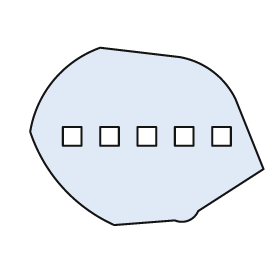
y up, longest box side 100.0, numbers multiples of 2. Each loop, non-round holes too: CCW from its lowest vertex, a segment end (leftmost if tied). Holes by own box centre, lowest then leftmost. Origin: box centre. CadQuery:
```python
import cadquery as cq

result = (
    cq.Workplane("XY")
    .moveTo(-14.0, -38.0)
    .lineTo(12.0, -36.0)
    .threePointArc((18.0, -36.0), (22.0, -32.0))
    .lineTo(50.0, -14.0)
    .lineTo(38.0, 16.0)
    .threePointArc((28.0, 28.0), (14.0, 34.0))
    .lineTo(-20.0, 38.0)
    .threePointArc((-40.0, 24.0), (-50.0, 2.0))
    .threePointArc((-36.0, -22.0), (-14.0, -38.0))
    .close()
    .moveTo(-36.0, -4.0)
    .lineTo(-28.0, -4.0)
    .lineTo(-28.0, 4.0)
    .lineTo(-36.0, 4.0)
    .close()
    .moveTo(-20.0, -4.0)
    .lineTo(-12.0, -4.0)
    .lineTo(-12.0, 4.0)
    .lineTo(-20.0, 4.0)
    .close()
    .moveTo(-4.0, -4.0)
    .lineTo(4.0, -4.0)
    .lineTo(4.0, 4.0)
    .lineTo(-4.0, 4.0)
    .close()
    .moveTo(12.0, -4.0)
    .lineTo(20.0, -4.0)
    .lineTo(20.0, 4.0)
    .lineTo(12.0, 4.0)
    .close()
    .moveTo(28.0, -4.0)
    .lineTo(36.0, -4.0)
    .lineTo(36.0, 4.0)
    .lineTo(28.0, 4.0)
    .close()
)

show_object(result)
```